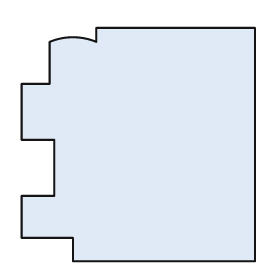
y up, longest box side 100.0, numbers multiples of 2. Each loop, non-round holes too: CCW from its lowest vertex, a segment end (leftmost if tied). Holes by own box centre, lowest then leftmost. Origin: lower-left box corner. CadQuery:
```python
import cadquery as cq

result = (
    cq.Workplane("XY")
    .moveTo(22.0, 0.0)
    .lineTo(100.0, 0.0)
    .lineTo(100.0, 100.0)
    .lineTo(32.0, 100.0)
    .lineTo(32.0, 94.0)
    .threePointArc((22.0, 96.0), (12.0, 94.0))
    .lineTo(12.0, 76.0)
    .lineTo(0.0, 76.0)
    .lineTo(0.0, 52.0)
    .lineTo(14.0, 52.0)
    .lineTo(14.0, 28.0)
    .lineTo(0.0, 28.0)
    .lineTo(0.0, 10.0)
    .lineTo(22.0, 10.0)
    .close()
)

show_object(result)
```